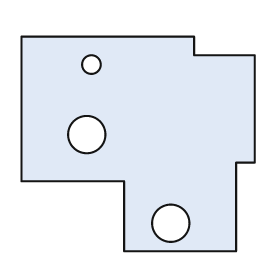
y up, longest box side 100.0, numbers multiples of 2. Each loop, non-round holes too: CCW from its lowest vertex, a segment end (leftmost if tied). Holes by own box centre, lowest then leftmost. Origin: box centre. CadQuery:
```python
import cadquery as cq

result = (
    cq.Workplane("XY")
    .moveTo(-6.0, -46.0)
    .lineTo(42.0, -46.0)
    .lineTo(42.0, -8.0)
    .lineTo(50.0, -8.0)
    .lineTo(50.0, 38.0)
    .lineTo(24.0, 38.0)
    .lineTo(24.0, 46.0)
    .lineTo(-50.0, 46.0)
    .lineTo(-50.0, -16.0)
    .lineTo(-6.0, -16.0)
    .close()
    .moveTo(14.0, -34.0)
    .circle(8.0)
    .moveTo(-22.0, 4.0)
    .circle(8.0)
    .moveTo(-20.0, 34.0)
    .circle(4.0)
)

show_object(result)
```